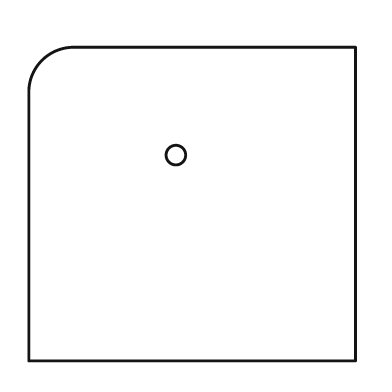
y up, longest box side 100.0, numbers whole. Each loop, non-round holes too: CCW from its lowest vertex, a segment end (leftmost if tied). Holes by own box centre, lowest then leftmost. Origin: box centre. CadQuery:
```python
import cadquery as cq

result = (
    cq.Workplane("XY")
    .moveTo(-50.0, -48.0)
    .lineTo(50.0, -48.0)
    .lineTo(50.0, 48.0)
    .lineTo(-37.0, 48.0)
    .threePointArc((-46.0, 44.0), (-50.0, 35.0))
    .close()
    .moveTo(-5.0, 15.0)
    .circle(3.0)
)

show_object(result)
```